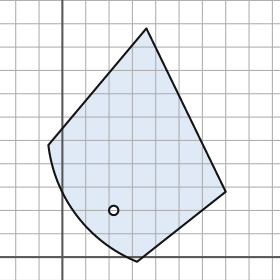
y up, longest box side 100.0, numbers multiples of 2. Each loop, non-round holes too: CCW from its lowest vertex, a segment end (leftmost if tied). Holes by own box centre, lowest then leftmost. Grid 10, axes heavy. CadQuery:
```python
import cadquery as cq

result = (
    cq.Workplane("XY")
    .moveTo(32.0, -2.0)
    .lineTo(70.0, 28.0)
    .lineTo(36.0, 98.0)
    .lineTo(-6.0, 48.0)
    .threePointArc((6.0, 18.0), (32.0, -2.0))
    .close()
    .moveTo(22.0, 20.0)
    .circle(2.0)
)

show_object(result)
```